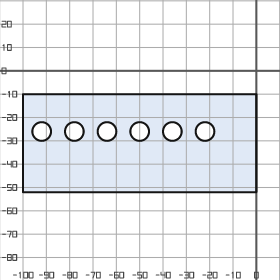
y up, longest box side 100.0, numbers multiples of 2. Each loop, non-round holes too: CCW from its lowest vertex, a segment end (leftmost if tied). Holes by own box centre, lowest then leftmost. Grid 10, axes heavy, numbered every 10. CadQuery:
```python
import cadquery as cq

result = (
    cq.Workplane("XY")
    .moveTo(-100.0, -52.0)
    .lineTo(0.0, -52.0)
    .lineTo(0.0, -10.0)
    .lineTo(-100.0, -10.0)
    .close()
    .moveTo(-92.0, -26.0)
    .circle(4.0)
    .moveTo(-78.0, -26.0)
    .circle(4.0)
    .moveTo(-64.0, -26.0)
    .circle(4.0)
    .moveTo(-50.0, -26.0)
    .circle(4.0)
    .moveTo(-36.0, -26.0)
    .circle(4.0)
    .moveTo(-22.0, -26.0)
    .circle(4.0)
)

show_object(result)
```